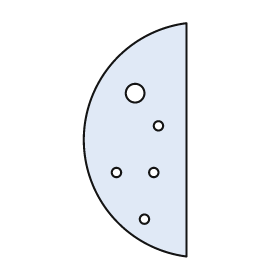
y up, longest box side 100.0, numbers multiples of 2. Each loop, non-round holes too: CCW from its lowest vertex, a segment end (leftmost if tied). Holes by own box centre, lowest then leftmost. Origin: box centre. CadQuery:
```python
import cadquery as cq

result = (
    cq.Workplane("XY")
    .moveTo(22.0, -50.0)
    .lineTo(22.0, 50.0)
    .threePointArc((-22.0, 0.0), (22.0, -50.0))
    .close()
    .moveTo(4.0, -34.0)
    .circle(2.0)
    .moveTo(-8.0, -14.0)
    .circle(2.0)
    .moveTo(8.0, -14.0)
    .circle(2.0)
    .moveTo(10.0, 6.0)
    .circle(2.0)
    .moveTo(0.0, 20.0)
    .circle(4.0)
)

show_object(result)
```